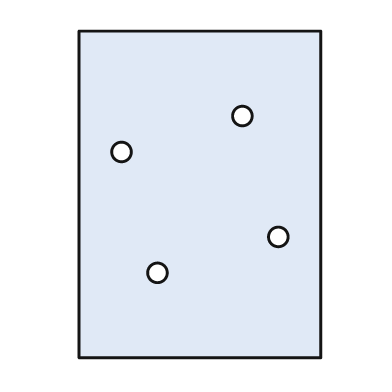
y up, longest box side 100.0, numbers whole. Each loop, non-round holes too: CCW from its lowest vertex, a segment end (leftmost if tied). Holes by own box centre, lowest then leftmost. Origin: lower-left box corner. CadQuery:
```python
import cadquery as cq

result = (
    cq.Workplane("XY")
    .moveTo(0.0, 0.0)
    .lineTo(74.0, 0.0)
    .lineTo(74.0, 100.0)
    .lineTo(0.0, 100.0)
    .close()
    .moveTo(24.0, 26.0)
    .circle(3.0)
    .moveTo(61.0, 37.0)
    .circle(3.0)
    .moveTo(13.0, 63.0)
    .circle(3.0)
    .moveTo(50.0, 74.0)
    .circle(3.0)
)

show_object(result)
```